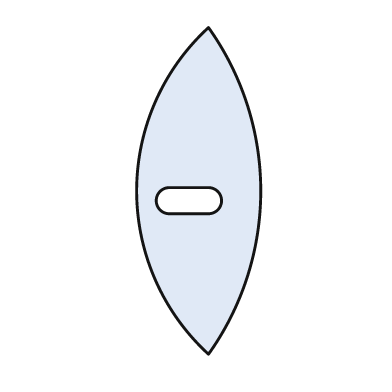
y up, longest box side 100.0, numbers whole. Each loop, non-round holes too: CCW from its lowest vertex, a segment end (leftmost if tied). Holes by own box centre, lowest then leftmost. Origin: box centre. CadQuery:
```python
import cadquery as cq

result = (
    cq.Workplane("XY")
    .moveTo(3.0, -50.0)
    .threePointArc((19.0, 0.0), (3.0, 50.0))
    .threePointArc((-19.0, 0.0), (3.0, -50.0))
    .close()
    .moveTo(-9.0, -7.0)
    .lineTo(3.0, -7.0)
    .threePointArc((7.0, -3.0), (3.0, 1.0))
    .lineTo(-9.0, 1.0)
    .threePointArc((-13.0, -3.0), (-9.0, -7.0))
    .close()
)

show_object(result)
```